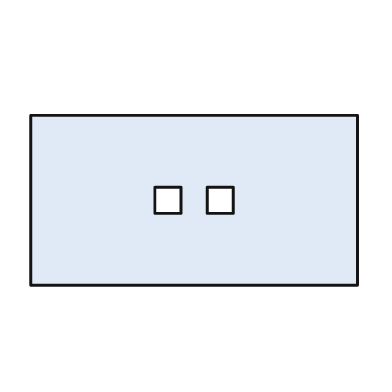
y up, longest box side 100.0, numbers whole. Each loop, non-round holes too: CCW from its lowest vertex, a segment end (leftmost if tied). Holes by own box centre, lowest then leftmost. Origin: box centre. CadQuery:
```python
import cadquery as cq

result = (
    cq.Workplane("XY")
    .moveTo(-50.0, -26.0)
    .lineTo(50.0, -26.0)
    .lineTo(50.0, 26.0)
    .lineTo(-50.0, 26.0)
    .close()
    .moveTo(-12.0, -4.0)
    .lineTo(-4.0, -4.0)
    .lineTo(-4.0, 4.0)
    .lineTo(-12.0, 4.0)
    .close()
    .moveTo(4.0, -4.0)
    .lineTo(12.0, -4.0)
    .lineTo(12.0, 4.0)
    .lineTo(4.0, 4.0)
    .close()
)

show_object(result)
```